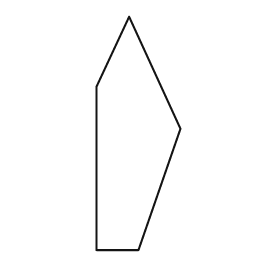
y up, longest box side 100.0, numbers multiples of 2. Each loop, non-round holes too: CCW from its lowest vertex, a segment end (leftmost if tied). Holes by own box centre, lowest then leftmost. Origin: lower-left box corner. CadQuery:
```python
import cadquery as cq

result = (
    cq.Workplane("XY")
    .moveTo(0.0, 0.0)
    .lineTo(18.0, 0.0)
    .lineTo(36.0, 52.0)
    .lineTo(14.0, 100.0)
    .lineTo(0.0, 70.0)
    .close()
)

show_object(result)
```